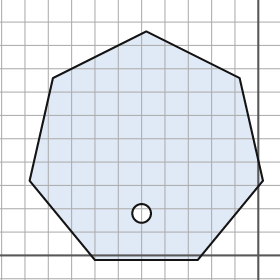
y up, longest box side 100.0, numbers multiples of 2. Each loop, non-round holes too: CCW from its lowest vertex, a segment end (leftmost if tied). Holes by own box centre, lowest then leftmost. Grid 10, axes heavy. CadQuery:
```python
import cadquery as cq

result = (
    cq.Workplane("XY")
    .moveTo(-70.0, -2.0)
    .lineTo(-26.0, -2.0)
    .lineTo(2.0, 32.0)
    .lineTo(-8.0, 76.0)
    .lineTo(-48.0, 96.0)
    .lineTo(-88.0, 76.0)
    .lineTo(-98.0, 32.0)
    .close()
    .moveTo(-50.0, 18.0)
    .circle(4.0)
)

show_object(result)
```